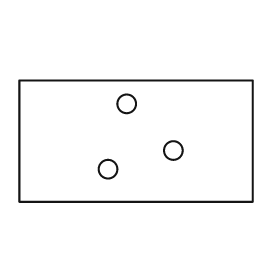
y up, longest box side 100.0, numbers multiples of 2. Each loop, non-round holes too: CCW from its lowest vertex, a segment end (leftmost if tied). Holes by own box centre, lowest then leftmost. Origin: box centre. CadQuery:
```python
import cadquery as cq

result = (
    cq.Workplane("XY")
    .moveTo(-50.0, -26.0)
    .lineTo(50.0, -26.0)
    .lineTo(50.0, 26.0)
    .lineTo(-50.0, 26.0)
    .close()
    .moveTo(-12.0, -12.0)
    .circle(4.0)
    .moveTo(16.0, -4.0)
    .circle(4.0)
    .moveTo(-4.0, 16.0)
    .circle(4.0)
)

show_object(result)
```